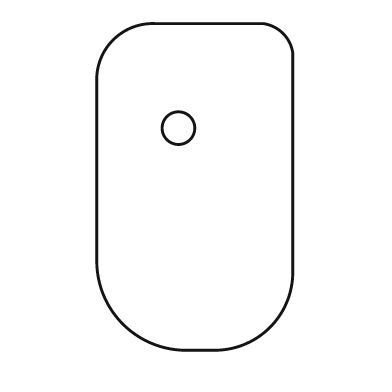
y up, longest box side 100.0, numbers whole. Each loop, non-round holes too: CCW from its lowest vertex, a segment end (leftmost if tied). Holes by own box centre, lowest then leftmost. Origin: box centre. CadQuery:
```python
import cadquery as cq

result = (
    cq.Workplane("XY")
    .moveTo(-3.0, -50.0)
    .lineTo(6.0, -50.0)
    .threePointArc((23.0, -43.0), (30.0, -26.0))
    .lineTo(30.0, 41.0)
    .threePointArc((27.0, 47.0), (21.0, 50.0))
    .lineTo(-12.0, 50.0)
    .threePointArc((-25.0, 45.0), (-30.0, 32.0))
    .lineTo(-30.0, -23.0)
    .threePointArc((-22.0, -42.0), (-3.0, -50.0))
    .close()
    .moveTo(-5.0, 18.0)
    .circle(5.0)
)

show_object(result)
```